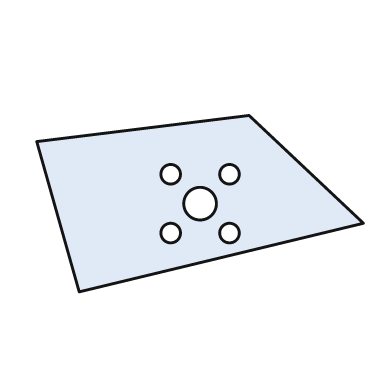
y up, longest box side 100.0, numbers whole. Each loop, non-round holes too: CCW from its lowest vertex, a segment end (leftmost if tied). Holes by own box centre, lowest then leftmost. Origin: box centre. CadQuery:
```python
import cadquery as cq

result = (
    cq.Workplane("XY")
    .moveTo(-37.0, -27.0)
    .lineTo(50.0, -6.0)
    .lineTo(15.0, 27.0)
    .lineTo(-50.0, 19.0)
    .close()
    .moveTo(-9.0, -9.0)
    .circle(3.0)
    .moveTo(9.0, -9.0)
    .circle(3.0)
    .moveTo(0.0, 0.0)
    .circle(5.0)
    .moveTo(-9.0, 9.0)
    .circle(3.0)
    .moveTo(9.0, 9.0)
    .circle(3.0)
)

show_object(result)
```